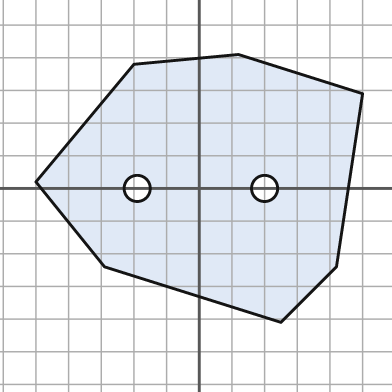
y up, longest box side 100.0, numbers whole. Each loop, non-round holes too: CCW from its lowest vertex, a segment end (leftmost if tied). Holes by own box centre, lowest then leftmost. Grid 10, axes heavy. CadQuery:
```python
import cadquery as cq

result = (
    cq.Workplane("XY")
    .moveTo(25.0, -41.0)
    .lineTo(42.0, -24.0)
    .lineTo(50.0, 29.0)
    .lineTo(12.0, 41.0)
    .lineTo(-20.0, 38.0)
    .lineTo(-50.0, 2.0)
    .lineTo(-29.0, -24.0)
    .close()
    .moveTo(-19.0, 0.0)
    .circle(4.0)
    .moveTo(20.0, 0.0)
    .circle(4.0)
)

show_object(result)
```